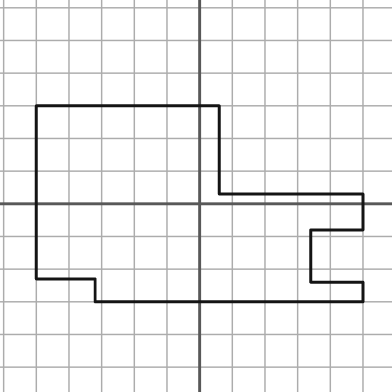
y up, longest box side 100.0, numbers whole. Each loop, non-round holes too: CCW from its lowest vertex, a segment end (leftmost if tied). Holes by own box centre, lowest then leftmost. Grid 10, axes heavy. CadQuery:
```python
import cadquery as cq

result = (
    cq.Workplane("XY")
    .moveTo(-32.0, -30.0)
    .lineTo(50.0, -30.0)
    .lineTo(50.0, -24.0)
    .lineTo(34.0, -24.0)
    .lineTo(34.0, -8.0)
    .lineTo(50.0, -8.0)
    .lineTo(50.0, 3.0)
    .lineTo(6.0, 3.0)
    .lineTo(6.0, 30.0)
    .lineTo(-50.0, 30.0)
    .lineTo(-50.0, -23.0)
    .lineTo(-32.0, -23.0)
    .close()
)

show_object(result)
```